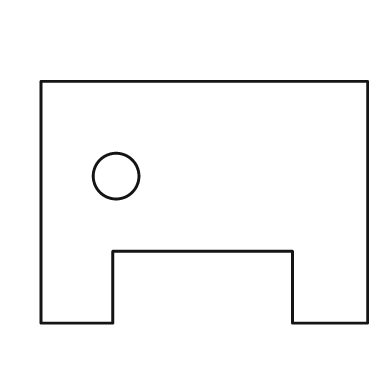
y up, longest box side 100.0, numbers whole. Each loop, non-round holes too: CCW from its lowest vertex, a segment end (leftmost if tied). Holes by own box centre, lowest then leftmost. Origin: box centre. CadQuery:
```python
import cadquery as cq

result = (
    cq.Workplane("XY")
    .moveTo(-50.0, -37.0)
    .lineTo(-28.0, -37.0)
    .lineTo(-28.0, -15.0)
    .lineTo(27.0, -15.0)
    .lineTo(27.0, -37.0)
    .lineTo(50.0, -37.0)
    .lineTo(50.0, 37.0)
    .lineTo(-50.0, 37.0)
    .close()
    .moveTo(-27.0, 8.0)
    .circle(7.0)
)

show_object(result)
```